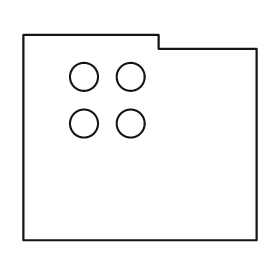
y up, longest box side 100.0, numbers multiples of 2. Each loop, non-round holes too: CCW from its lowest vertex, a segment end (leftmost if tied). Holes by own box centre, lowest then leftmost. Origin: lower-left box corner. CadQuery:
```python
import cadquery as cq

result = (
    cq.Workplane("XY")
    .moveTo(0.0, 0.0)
    .lineTo(100.0, 0.0)
    .lineTo(100.0, 82.0)
    .lineTo(58.0, 82.0)
    .lineTo(58.0, 88.0)
    .lineTo(0.0, 88.0)
    .close()
    .moveTo(26.0, 50.0)
    .circle(6.0)
    .moveTo(46.0, 50.0)
    .circle(6.0)
    .moveTo(26.0, 70.0)
    .circle(6.0)
    .moveTo(46.0, 70.0)
    .circle(6.0)
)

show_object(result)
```